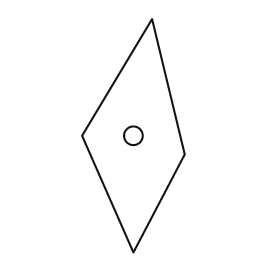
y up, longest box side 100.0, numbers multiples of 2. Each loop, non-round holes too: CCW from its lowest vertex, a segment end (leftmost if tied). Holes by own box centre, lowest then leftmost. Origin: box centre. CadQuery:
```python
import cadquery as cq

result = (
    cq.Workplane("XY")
    .moveTo(0.0, -50.0)
    .lineTo(22.0, -8.0)
    .lineTo(8.0, 50.0)
    .lineTo(-22.0, 0.0)
    .close()
    .moveTo(0.0, 0.0)
    .circle(4.0)
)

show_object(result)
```